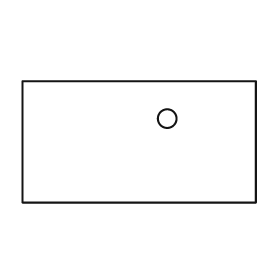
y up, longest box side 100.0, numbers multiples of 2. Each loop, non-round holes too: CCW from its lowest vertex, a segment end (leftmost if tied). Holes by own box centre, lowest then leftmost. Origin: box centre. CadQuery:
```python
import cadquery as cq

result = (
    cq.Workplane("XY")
    .moveTo(-50.0, -26.0)
    .lineTo(50.0, -26.0)
    .lineTo(50.0, 26.0)
    .lineTo(-50.0, 26.0)
    .close()
    .moveTo(12.0, 10.0)
    .circle(4.0)
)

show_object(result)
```